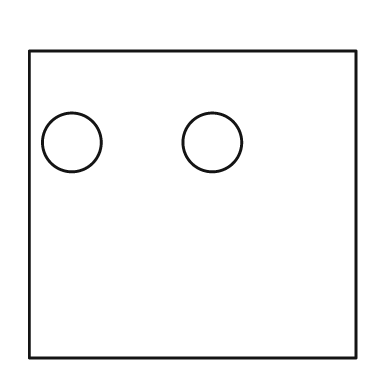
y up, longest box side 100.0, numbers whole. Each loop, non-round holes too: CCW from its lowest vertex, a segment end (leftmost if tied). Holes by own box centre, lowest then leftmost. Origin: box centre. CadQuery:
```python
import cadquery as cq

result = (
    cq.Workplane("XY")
    .moveTo(-50.0, -47.0)
    .lineTo(50.0, -47.0)
    .lineTo(50.0, 47.0)
    .lineTo(-50.0, 47.0)
    .close()
    .moveTo(-37.0, 19.0)
    .circle(9.0)
    .moveTo(6.0, 19.0)
    .circle(9.0)
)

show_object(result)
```